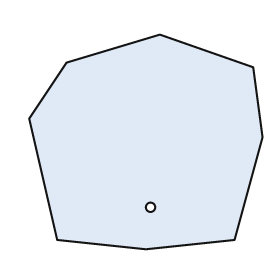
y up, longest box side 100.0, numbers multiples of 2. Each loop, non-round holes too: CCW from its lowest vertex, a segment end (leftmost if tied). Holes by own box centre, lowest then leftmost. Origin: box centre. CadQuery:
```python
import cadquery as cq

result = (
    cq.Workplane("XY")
    .moveTo(0.0, -46.0)
    .lineTo(38.0, -42.0)
    .lineTo(50.0, 2.0)
    .lineTo(46.0, 32.0)
    .lineTo(6.0, 46.0)
    .lineTo(-34.0, 34.0)
    .lineTo(-50.0, 10.0)
    .lineTo(-38.0, -42.0)
    .close()
    .moveTo(2.0, -28.0)
    .circle(2.0)
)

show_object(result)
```